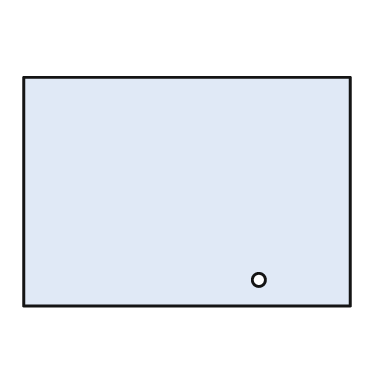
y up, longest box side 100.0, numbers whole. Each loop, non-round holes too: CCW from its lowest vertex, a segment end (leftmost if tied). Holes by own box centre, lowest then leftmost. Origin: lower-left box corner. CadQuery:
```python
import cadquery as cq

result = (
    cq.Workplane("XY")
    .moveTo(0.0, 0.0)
    .lineTo(100.0, 0.0)
    .lineTo(100.0, 70.0)
    .lineTo(0.0, 70.0)
    .close()
    .moveTo(72.0, 8.0)
    .circle(2.0)
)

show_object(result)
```